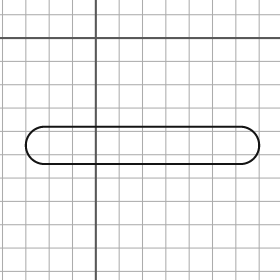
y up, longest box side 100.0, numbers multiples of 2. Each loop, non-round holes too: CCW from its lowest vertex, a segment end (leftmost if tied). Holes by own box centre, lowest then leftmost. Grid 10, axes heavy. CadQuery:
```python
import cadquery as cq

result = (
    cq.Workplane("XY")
    .moveTo(-22.0, -54.0)
    .lineTo(62.0, -54.0)
    .threePointArc((70.0, -46.0), (62.0, -38.0))
    .lineTo(-22.0, -38.0)
    .threePointArc((-30.0, -46.0), (-22.0, -54.0))
    .close()
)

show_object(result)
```